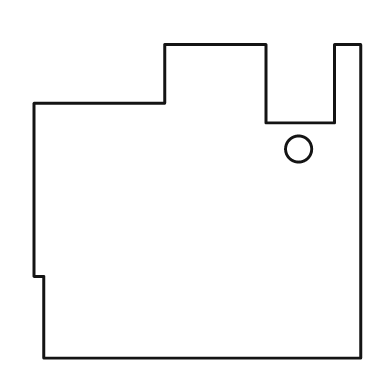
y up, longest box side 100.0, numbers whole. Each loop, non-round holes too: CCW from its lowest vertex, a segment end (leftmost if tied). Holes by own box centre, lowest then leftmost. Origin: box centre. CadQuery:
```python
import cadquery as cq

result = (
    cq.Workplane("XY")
    .moveTo(-47.0, -48.0)
    .lineTo(50.0, -48.0)
    .lineTo(50.0, 48.0)
    .lineTo(42.0, 48.0)
    .lineTo(42.0, 24.0)
    .lineTo(21.0, 24.0)
    .lineTo(21.0, 48.0)
    .lineTo(-10.0, 48.0)
    .lineTo(-10.0, 30.0)
    .lineTo(-50.0, 30.0)
    .lineTo(-50.0, -23.0)
    .lineTo(-47.0, -23.0)
    .close()
    .moveTo(31.0, 16.0)
    .circle(4.0)
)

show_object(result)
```